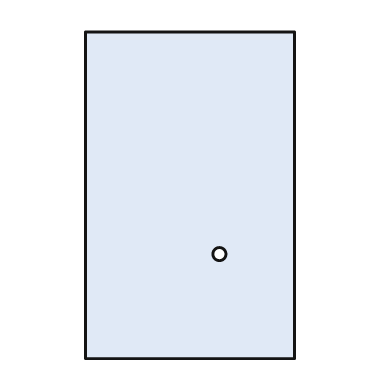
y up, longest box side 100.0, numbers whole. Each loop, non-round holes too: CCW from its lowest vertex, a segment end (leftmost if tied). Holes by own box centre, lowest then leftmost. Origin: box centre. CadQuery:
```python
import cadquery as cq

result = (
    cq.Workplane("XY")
    .moveTo(-32.0, -50.0)
    .lineTo(32.0, -50.0)
    .lineTo(32.0, 50.0)
    .lineTo(-32.0, 50.0)
    .close()
    .moveTo(9.0, -18.0)
    .circle(2.0)
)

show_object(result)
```